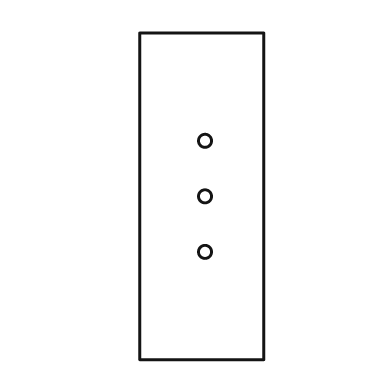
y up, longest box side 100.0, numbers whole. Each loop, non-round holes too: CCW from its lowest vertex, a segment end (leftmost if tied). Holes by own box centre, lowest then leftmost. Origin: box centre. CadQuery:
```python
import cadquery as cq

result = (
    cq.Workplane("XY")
    .moveTo(-19.0, -50.0)
    .lineTo(19.0, -50.0)
    .lineTo(19.0, 50.0)
    .lineTo(-19.0, 50.0)
    .close()
    .moveTo(1.0, -17.0)
    .circle(2.0)
    .moveTo(1.0, 0.0)
    .circle(2.0)
    .moveTo(1.0, 17.0)
    .circle(2.0)
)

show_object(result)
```